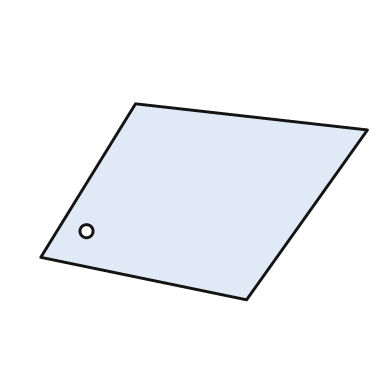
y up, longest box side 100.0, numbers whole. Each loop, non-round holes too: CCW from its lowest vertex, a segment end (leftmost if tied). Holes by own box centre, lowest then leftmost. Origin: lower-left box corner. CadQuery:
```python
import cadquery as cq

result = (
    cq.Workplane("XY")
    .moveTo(63.0, 0.0)
    .lineTo(100.0, 52.0)
    .lineTo(29.0, 60.0)
    .lineTo(0.0, 13.0)
    .close()
    .moveTo(14.0, 21.0)
    .circle(2.0)
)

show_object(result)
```